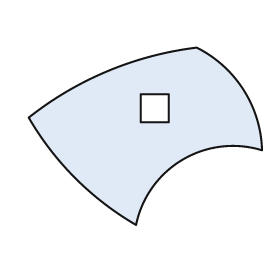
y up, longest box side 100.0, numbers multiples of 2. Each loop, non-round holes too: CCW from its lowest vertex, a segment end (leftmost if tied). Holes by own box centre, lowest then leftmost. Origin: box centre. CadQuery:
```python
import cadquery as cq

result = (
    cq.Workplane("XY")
    .moveTo(-4.0, -38.0)
    .threePointArc((16.0, -10.0), (50.0, -6.0))
    .threePointArc((42.0, 20.0), (22.0, 38.0))
    .threePointArc((-16.0, 28.0), (-50.0, 8.0))
    .threePointArc((-30.0, -18.0), (-4.0, -38.0))
    .close()
    .moveTo(-2.0, 6.0)
    .lineTo(10.0, 6.0)
    .lineTo(10.0, 18.0)
    .lineTo(-2.0, 18.0)
    .close()
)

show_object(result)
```